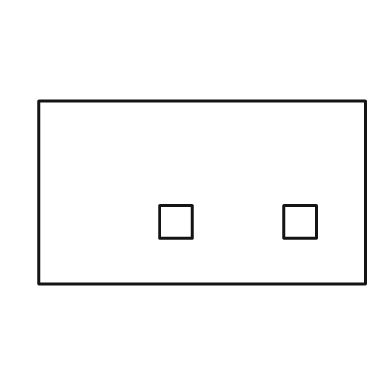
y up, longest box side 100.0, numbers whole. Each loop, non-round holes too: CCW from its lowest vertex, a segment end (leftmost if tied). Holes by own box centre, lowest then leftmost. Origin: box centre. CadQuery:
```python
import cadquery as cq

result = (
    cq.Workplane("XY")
    .moveTo(-50.0, -28.0)
    .lineTo(50.0, -28.0)
    .lineTo(50.0, 28.0)
    .lineTo(-50.0, 28.0)
    .close()
    .moveTo(-13.0, -14.0)
    .lineTo(-3.0, -14.0)
    .lineTo(-3.0, -4.0)
    .lineTo(-13.0, -4.0)
    .close()
    .moveTo(25.0, -14.0)
    .lineTo(35.0, -14.0)
    .lineTo(35.0, -4.0)
    .lineTo(25.0, -4.0)
    .close()
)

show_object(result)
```